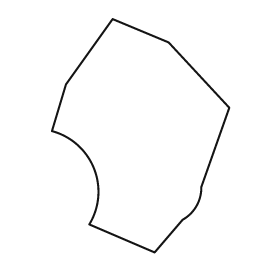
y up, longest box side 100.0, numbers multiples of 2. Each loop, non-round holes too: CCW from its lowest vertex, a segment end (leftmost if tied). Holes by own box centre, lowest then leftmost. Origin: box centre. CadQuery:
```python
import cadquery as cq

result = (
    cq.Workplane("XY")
    .moveTo(6.0, -50.0)
    .lineTo(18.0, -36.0)
    .threePointArc((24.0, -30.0), (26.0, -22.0))
    .lineTo(38.0, 12.0)
    .lineTo(12.0, 40.0)
    .lineTo(-12.0, 50.0)
    .lineTo(-32.0, 22.0)
    .lineTo(-38.0, 2.0)
    .threePointArc((-20.0, -14.0), (-22.0, -38.0))
    .close()
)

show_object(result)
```